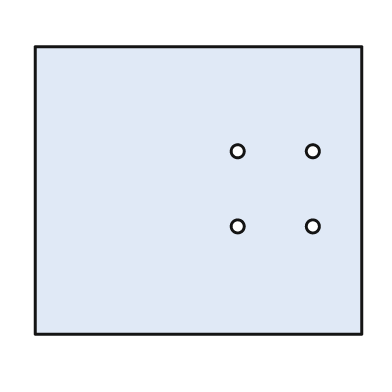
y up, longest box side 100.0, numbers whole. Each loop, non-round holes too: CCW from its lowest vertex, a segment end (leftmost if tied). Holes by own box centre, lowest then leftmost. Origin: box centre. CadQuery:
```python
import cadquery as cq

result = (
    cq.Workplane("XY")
    .moveTo(-50.0, -44.0)
    .lineTo(50.0, -44.0)
    .lineTo(50.0, 44.0)
    .lineTo(-50.0, 44.0)
    .close()
    .moveTo(12.0, -11.0)
    .circle(2.0)
    .moveTo(35.0, -11.0)
    .circle(2.0)
    .moveTo(12.0, 12.0)
    .circle(2.0)
    .moveTo(35.0, 12.0)
    .circle(2.0)
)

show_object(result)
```